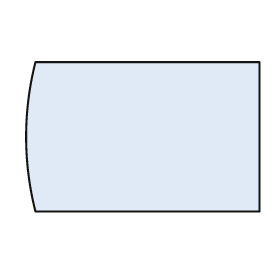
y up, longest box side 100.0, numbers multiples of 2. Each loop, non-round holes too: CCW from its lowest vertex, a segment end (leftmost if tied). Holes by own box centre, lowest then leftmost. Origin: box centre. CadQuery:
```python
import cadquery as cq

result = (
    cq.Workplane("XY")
    .moveTo(-46.0, -32.0)
    .lineTo(50.0, -32.0)
    .lineTo(50.0, 32.0)
    .lineTo(-46.0, 32.0)
    .threePointArc((-50.0, 0.0), (-46.0, -32.0))
    .close()
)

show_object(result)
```